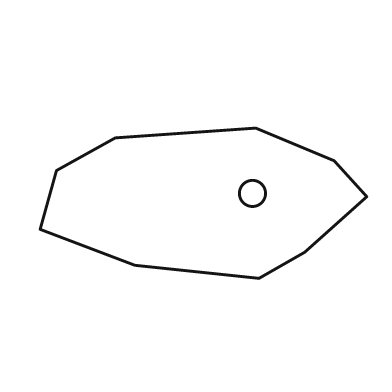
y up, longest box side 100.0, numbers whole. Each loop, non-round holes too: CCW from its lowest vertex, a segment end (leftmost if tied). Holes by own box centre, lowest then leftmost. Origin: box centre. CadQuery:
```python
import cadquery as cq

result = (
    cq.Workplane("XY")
    .moveTo(17.0, -23.0)
    .lineTo(31.0, -15.0)
    .lineTo(50.0, 2.0)
    .lineTo(40.0, 13.0)
    .lineTo(16.0, 23.0)
    .lineTo(-27.0, 20.0)
    .lineTo(-45.0, 10.0)
    .lineTo(-50.0, -8.0)
    .lineTo(-21.0, -19.0)
    .close()
    .moveTo(15.0, 3.0)
    .circle(4.0)
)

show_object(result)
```